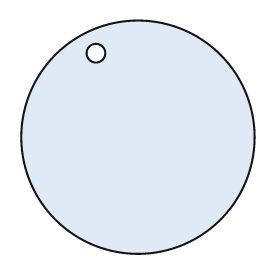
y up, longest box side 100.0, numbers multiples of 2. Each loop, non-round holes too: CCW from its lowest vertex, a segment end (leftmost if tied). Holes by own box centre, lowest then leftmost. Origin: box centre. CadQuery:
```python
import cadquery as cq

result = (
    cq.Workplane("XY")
    .moveTo(0.0, 0.0)
    .circle(50.0)
    .moveTo(-18.0, 36.0)
    .circle(4.0)
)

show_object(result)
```